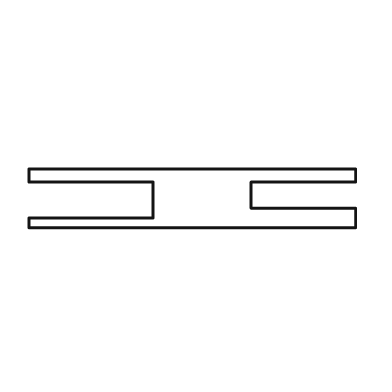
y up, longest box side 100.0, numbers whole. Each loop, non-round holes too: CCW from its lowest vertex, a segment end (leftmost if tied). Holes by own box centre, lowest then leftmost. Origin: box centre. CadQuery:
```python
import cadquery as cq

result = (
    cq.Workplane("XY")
    .moveTo(-50.0, -9.0)
    .lineTo(50.0, -9.0)
    .lineTo(50.0, -3.0)
    .lineTo(18.0, -3.0)
    .lineTo(18.0, 5.0)
    .lineTo(50.0, 5.0)
    .lineTo(50.0, 9.0)
    .lineTo(-50.0, 9.0)
    .lineTo(-50.0, 5.0)
    .lineTo(-12.0, 5.0)
    .lineTo(-12.0, -6.0)
    .lineTo(-50.0, -6.0)
    .close()
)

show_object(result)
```